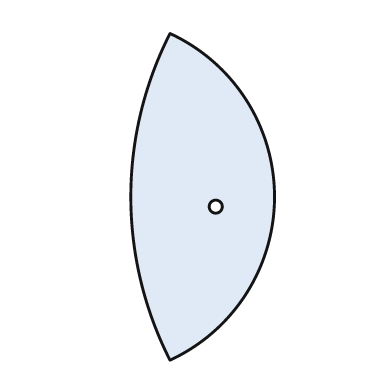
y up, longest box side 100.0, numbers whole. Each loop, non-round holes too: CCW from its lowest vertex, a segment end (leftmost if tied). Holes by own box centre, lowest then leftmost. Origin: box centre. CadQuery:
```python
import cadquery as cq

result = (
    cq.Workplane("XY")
    .moveTo(-10.0, -50.0)
    .threePointArc((22.0, 0.0), (-10.0, 50.0))
    .threePointArc((-22.0, 0.0), (-10.0, -50.0))
    .close()
    .moveTo(4.0, -3.0)
    .circle(2.0)
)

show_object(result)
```